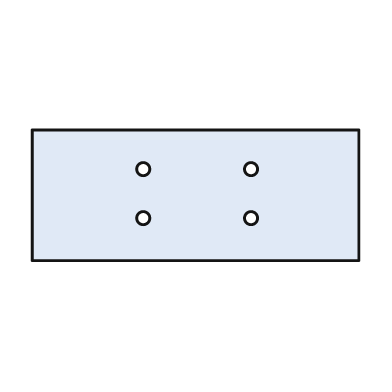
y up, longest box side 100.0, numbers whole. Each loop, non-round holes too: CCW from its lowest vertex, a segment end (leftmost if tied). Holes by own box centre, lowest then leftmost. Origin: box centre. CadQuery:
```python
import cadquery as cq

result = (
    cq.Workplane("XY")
    .moveTo(-50.0, -20.0)
    .lineTo(50.0, -20.0)
    .lineTo(50.0, 20.0)
    .lineTo(-50.0, 20.0)
    .close()
    .moveTo(-16.0, -7.0)
    .circle(2.0)
    .moveTo(17.0, -7.0)
    .circle(2.0)
    .moveTo(-16.0, 8.0)
    .circle(2.0)
    .moveTo(17.0, 8.0)
    .circle(2.0)
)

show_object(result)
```